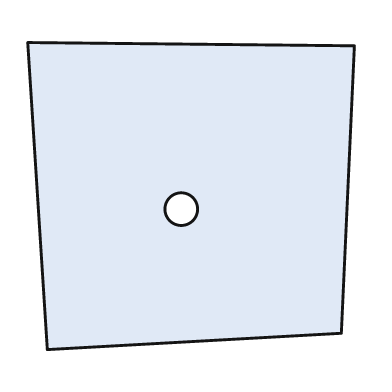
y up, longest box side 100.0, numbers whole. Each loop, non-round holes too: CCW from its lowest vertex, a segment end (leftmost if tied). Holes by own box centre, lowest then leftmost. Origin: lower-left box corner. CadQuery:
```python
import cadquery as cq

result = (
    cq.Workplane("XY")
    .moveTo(6.0, 0.0)
    .lineTo(96.0, 5.0)
    .lineTo(100.0, 93.0)
    .lineTo(0.0, 94.0)
    .close()
    .moveTo(47.0, 43.0)
    .circle(5.0)
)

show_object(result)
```